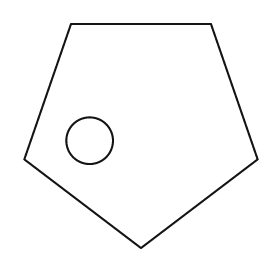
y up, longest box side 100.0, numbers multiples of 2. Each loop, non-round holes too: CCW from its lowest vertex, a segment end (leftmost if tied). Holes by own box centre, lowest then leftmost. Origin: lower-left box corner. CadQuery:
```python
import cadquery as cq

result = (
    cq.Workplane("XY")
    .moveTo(50.0, 0.0)
    .lineTo(100.0, 38.0)
    .lineTo(80.0, 96.0)
    .lineTo(20.0, 96.0)
    .lineTo(0.0, 38.0)
    .close()
    .moveTo(28.0, 46.0)
    .circle(10.0)
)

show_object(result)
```